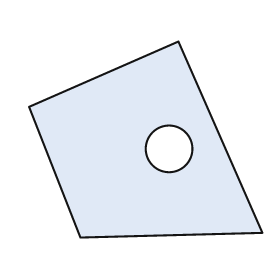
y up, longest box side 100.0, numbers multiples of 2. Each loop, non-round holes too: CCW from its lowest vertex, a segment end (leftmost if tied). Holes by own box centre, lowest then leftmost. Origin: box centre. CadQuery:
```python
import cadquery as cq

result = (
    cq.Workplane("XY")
    .moveTo(-28.0, -42.0)
    .lineTo(50.0, -40.0)
    .lineTo(14.0, 42.0)
    .lineTo(-50.0, 14.0)
    .close()
    .moveTo(10.0, -4.0)
    .circle(10.0)
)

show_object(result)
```